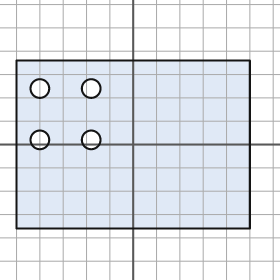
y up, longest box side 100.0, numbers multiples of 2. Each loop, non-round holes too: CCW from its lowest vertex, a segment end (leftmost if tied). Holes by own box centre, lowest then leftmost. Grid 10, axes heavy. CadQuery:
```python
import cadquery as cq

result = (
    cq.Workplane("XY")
    .moveTo(-50.0, -36.0)
    .lineTo(50.0, -36.0)
    .lineTo(50.0, 36.0)
    .lineTo(-50.0, 36.0)
    .close()
    .moveTo(-40.0, 2.0)
    .circle(4.0)
    .moveTo(-18.0, 2.0)
    .circle(4.0)
    .moveTo(-40.0, 24.0)
    .circle(4.0)
    .moveTo(-18.0, 24.0)
    .circle(4.0)
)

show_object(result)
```